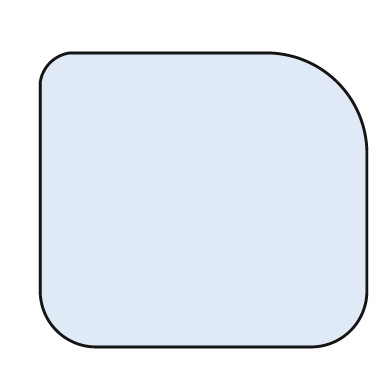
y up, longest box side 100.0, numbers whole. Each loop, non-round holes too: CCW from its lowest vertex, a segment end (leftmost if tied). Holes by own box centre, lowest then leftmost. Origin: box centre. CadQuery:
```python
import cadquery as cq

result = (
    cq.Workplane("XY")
    .moveTo(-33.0, -45.0)
    .lineTo(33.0, -45.0)
    .threePointArc((45.0, -40.0), (50.0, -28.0))
    .lineTo(50.0, 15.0)
    .threePointArc((41.0, 36.0), (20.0, 45.0))
    .lineTo(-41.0, 45.0)
    .threePointArc((-47.0, 42.0), (-50.0, 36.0))
    .lineTo(-50.0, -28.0)
    .threePointArc((-45.0, -40.0), (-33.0, -45.0))
    .close()
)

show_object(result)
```